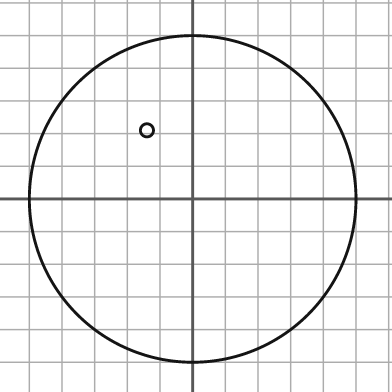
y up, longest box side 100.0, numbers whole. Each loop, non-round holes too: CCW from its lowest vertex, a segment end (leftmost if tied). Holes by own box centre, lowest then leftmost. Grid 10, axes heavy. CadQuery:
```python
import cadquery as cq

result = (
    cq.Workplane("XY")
    .moveTo(0.0, 0.0)
    .circle(50.0)
    .moveTo(-14.0, 21.0)
    .circle(2.0)
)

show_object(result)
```